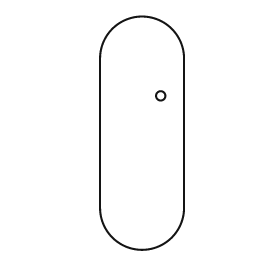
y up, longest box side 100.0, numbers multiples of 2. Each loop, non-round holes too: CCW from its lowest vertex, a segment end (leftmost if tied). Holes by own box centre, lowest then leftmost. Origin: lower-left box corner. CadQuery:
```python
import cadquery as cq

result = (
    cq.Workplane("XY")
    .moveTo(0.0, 18.0)
    .threePointArc((18.0, 0.0), (36.0, 18.0))
    .lineTo(36.0, 82.0)
    .threePointArc((18.0, 100.0), (0.0, 82.0))
    .close()
    .moveTo(26.0, 66.0)
    .circle(2.0)
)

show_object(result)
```